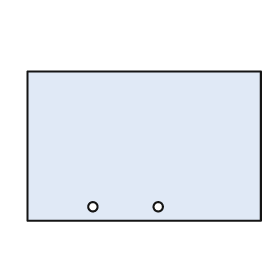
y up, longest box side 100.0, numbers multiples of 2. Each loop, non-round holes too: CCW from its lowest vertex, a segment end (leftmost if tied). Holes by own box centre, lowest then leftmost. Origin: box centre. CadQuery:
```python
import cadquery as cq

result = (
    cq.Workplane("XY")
    .moveTo(-50.0, -32.0)
    .lineTo(50.0, -32.0)
    .lineTo(50.0, 32.0)
    .lineTo(-50.0, 32.0)
    .close()
    .moveTo(-22.0, -26.0)
    .circle(2.0)
    .moveTo(6.0, -26.0)
    .circle(2.0)
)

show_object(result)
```